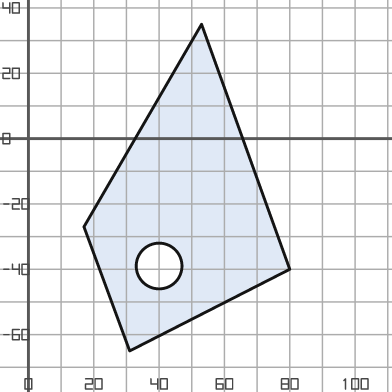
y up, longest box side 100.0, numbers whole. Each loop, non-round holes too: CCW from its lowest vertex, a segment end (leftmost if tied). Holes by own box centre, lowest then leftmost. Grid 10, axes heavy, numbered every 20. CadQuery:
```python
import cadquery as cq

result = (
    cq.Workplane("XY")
    .moveTo(31.0, -65.0)
    .lineTo(80.0, -40.0)
    .lineTo(53.0, 35.0)
    .lineTo(17.0, -27.0)
    .close()
    .moveTo(40.0, -39.0)
    .circle(7.0)
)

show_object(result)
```